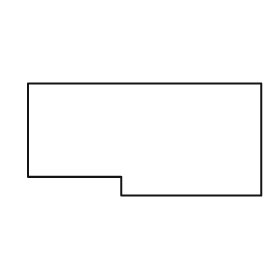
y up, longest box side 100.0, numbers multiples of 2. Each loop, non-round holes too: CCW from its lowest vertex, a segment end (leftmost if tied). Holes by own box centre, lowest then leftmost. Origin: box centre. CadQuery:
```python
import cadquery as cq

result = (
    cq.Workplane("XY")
    .moveTo(-10.0, -24.0)
    .lineTo(50.0, -24.0)
    .lineTo(50.0, 24.0)
    .lineTo(-50.0, 24.0)
    .lineTo(-50.0, -16.0)
    .lineTo(-10.0, -16.0)
    .close()
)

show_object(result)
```